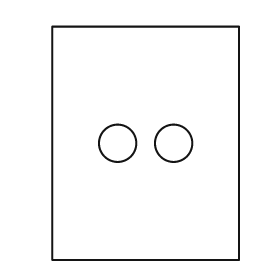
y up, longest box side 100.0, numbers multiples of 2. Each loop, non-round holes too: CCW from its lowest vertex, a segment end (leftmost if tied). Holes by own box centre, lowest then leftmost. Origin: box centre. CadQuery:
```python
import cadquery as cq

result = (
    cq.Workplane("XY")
    .moveTo(-40.0, -50.0)
    .lineTo(40.0, -50.0)
    .lineTo(40.0, 50.0)
    .lineTo(-40.0, 50.0)
    .close()
    .moveTo(-12.0, 0.0)
    .circle(8.0)
    .moveTo(12.0, 0.0)
    .circle(8.0)
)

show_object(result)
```